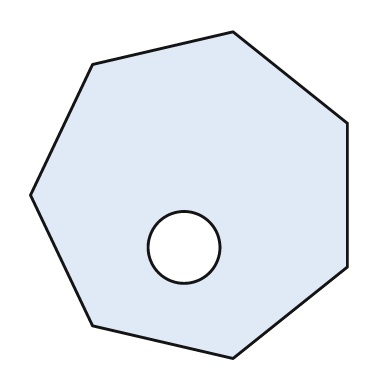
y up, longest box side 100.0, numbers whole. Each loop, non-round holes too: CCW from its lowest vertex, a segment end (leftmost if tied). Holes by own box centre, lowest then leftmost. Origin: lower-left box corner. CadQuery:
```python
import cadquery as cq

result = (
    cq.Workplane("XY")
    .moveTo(62.0, 0.0)
    .lineTo(97.0, 28.0)
    .lineTo(97.0, 72.0)
    .lineTo(62.0, 100.0)
    .lineTo(19.0, 90.0)
    .lineTo(0.0, 50.0)
    .lineTo(19.0, 10.0)
    .close()
    .moveTo(47.0, 34.0)
    .circle(11.0)
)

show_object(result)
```